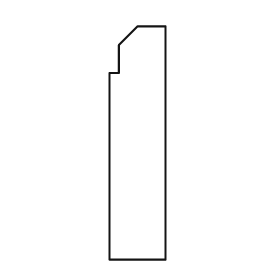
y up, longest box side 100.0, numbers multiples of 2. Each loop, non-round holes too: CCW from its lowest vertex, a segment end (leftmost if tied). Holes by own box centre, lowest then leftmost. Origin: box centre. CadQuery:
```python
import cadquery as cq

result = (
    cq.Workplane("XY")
    .moveTo(-12.0, -50.0)
    .lineTo(12.0, -50.0)
    .lineTo(12.0, 50.0)
    .lineTo(0.0, 50.0)
    .lineTo(-8.0, 42.0)
    .lineTo(-8.0, 30.0)
    .lineTo(-12.0, 30.0)
    .close()
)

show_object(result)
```